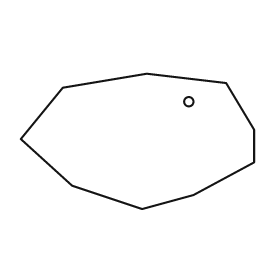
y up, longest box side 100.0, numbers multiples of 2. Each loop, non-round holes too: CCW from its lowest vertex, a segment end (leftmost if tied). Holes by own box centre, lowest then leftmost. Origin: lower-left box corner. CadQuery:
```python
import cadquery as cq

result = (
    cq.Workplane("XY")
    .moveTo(52.0, 0.0)
    .lineTo(74.0, 6.0)
    .lineTo(100.0, 20.0)
    .lineTo(100.0, 34.0)
    .lineTo(88.0, 54.0)
    .lineTo(54.0, 58.0)
    .lineTo(18.0, 52.0)
    .lineTo(0.0, 30.0)
    .lineTo(22.0, 10.0)
    .close()
    .moveTo(72.0, 46.0)
    .circle(2.0)
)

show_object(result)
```